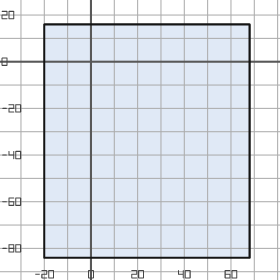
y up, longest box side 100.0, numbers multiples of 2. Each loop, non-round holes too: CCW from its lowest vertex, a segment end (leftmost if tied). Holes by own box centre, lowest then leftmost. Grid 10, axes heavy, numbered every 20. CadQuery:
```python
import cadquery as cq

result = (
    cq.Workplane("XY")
    .moveTo(-20.0, -84.0)
    .lineTo(68.0, -84.0)
    .lineTo(68.0, 16.0)
    .lineTo(-20.0, 16.0)
    .close()
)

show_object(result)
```